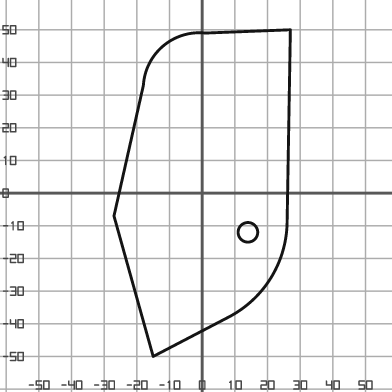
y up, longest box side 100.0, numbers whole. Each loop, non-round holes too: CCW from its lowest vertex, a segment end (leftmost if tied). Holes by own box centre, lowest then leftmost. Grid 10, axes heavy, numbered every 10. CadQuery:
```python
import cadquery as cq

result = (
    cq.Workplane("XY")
    .moveTo(-15.0, -50.0)
    .lineTo(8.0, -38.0)
    .threePointArc((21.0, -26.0), (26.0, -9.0))
    .lineTo(27.0, 50.0)
    .lineTo(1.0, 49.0)
    .threePointArc((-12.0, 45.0), (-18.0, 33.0))
    .lineTo(-27.0, -7.0)
    .close()
    .moveTo(14.0, -12.0)
    .circle(3.0)
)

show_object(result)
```